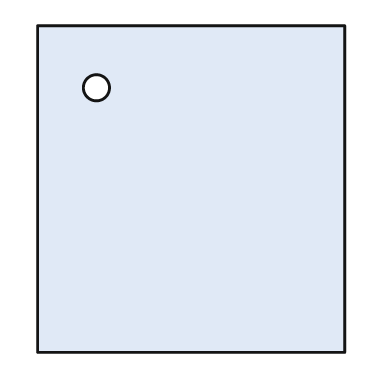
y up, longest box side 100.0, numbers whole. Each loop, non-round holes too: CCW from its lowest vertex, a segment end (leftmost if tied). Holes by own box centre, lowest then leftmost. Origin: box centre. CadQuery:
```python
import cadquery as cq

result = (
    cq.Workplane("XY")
    .moveTo(-47.0, -50.0)
    .lineTo(47.0, -50.0)
    .lineTo(47.0, 50.0)
    .lineTo(-47.0, 50.0)
    .close()
    .moveTo(-29.0, 31.0)
    .circle(4.0)
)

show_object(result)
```